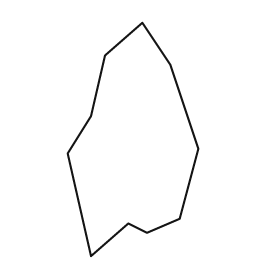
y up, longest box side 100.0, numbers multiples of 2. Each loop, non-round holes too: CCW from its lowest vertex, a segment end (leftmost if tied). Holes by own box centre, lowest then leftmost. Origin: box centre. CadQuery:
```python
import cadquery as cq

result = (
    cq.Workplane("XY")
    .moveTo(-18.0, -50.0)
    .lineTo(-2.0, -36.0)
    .lineTo(6.0, -40.0)
    .lineTo(20.0, -34.0)
    .lineTo(28.0, -4.0)
    .lineTo(16.0, 32.0)
    .lineTo(4.0, 50.0)
    .lineTo(-12.0, 36.0)
    .lineTo(-18.0, 10.0)
    .lineTo(-28.0, -6.0)
    .close()
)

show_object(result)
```